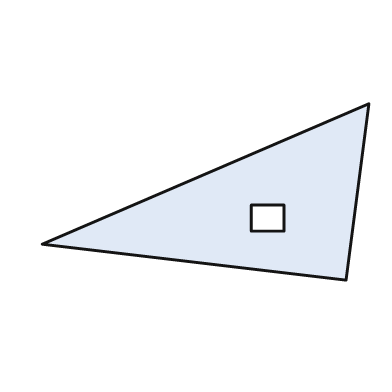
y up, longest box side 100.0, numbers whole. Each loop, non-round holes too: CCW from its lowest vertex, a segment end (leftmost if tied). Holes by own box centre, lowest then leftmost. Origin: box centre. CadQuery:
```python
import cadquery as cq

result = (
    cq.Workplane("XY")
    .moveTo(43.0, -27.0)
    .lineTo(50.0, 27.0)
    .lineTo(-50.0, -16.0)
    .close()
    .moveTo(14.0, -12.0)
    .lineTo(24.0, -12.0)
    .lineTo(24.0, -4.0)
    .lineTo(14.0, -4.0)
    .close()
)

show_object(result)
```